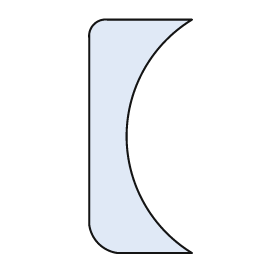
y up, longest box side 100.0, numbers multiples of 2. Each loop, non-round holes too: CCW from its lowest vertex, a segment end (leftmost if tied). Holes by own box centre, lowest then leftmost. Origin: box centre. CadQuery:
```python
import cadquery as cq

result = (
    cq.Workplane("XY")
    .moveTo(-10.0, -50.0)
    .lineTo(22.0, -50.0)
    .threePointArc((-6.0, 0.0), (22.0, 50.0))
    .lineTo(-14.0, 50.0)
    .threePointArc((-20.0, 48.0), (-22.0, 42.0))
    .lineTo(-22.0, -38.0)
    .threePointArc((-18.0, -46.0), (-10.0, -50.0))
    .close()
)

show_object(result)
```